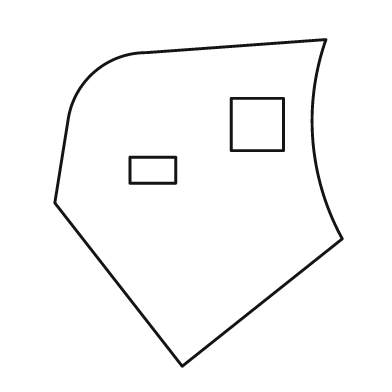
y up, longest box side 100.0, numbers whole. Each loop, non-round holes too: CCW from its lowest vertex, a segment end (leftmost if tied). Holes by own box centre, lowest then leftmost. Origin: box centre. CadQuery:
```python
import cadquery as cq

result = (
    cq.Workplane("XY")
    .moveTo(-5.0, -50.0)
    .lineTo(44.0, -11.0)
    .threePointArc((35.0, 19.0), (39.0, 50.0))
    .lineTo(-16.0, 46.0)
    .threePointArc((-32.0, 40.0), (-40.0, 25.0))
    .lineTo(-44.0, 0.0)
    .close()
    .moveTo(-21.0, 6.0)
    .lineTo(-7.0, 6.0)
    .lineTo(-7.0, 14.0)
    .lineTo(-21.0, 14.0)
    .close()
    .moveTo(10.0, 16.0)
    .lineTo(26.0, 16.0)
    .lineTo(26.0, 32.0)
    .lineTo(10.0, 32.0)
    .close()
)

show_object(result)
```